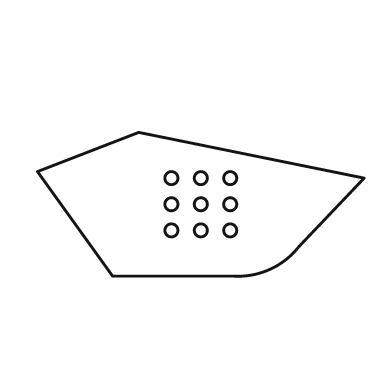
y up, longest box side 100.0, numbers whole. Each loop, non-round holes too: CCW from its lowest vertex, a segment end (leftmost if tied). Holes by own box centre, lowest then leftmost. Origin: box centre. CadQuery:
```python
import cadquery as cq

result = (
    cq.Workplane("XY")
    .moveTo(-27.0, -22.0)
    .lineTo(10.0, -22.0)
    .threePointArc((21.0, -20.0), (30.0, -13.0))
    .lineTo(50.0, 8.0)
    .lineTo(-19.0, 22.0)
    .lineTo(-50.0, 10.0)
    .close()
    .moveTo(-9.0, -8.0)
    .circle(2.0)
    .moveTo(0.0, -8.0)
    .circle(2.0)
    .moveTo(9.0, -8.0)
    .circle(2.0)
    .moveTo(-9.0, 0.0)
    .circle(2.0)
    .moveTo(0.0, 0.0)
    .circle(2.0)
    .moveTo(9.0, 0.0)
    .circle(2.0)
    .moveTo(-9.0, 8.0)
    .circle(2.0)
    .moveTo(0.0, 8.0)
    .circle(2.0)
    .moveTo(9.0, 8.0)
    .circle(2.0)
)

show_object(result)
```